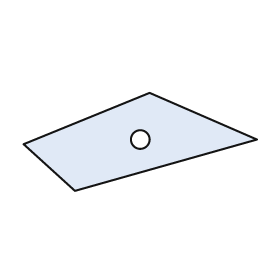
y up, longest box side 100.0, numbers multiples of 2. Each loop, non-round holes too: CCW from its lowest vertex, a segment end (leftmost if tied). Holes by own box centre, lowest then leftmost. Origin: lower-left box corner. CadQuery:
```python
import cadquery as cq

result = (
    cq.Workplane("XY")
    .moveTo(22.0, 0.0)
    .lineTo(100.0, 22.0)
    .lineTo(54.0, 42.0)
    .lineTo(0.0, 20.0)
    .close()
    .moveTo(50.0, 22.0)
    .circle(4.0)
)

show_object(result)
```